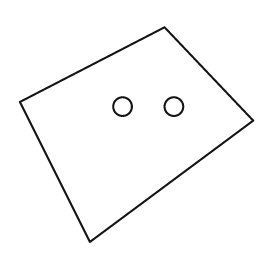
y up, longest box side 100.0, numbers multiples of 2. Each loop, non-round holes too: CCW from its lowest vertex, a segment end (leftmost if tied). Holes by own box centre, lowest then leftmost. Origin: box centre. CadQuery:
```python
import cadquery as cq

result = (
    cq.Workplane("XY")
    .moveTo(-20.0, -46.0)
    .lineTo(50.0, 6.0)
    .lineTo(12.0, 46.0)
    .lineTo(-50.0, 14.0)
    .close()
    .moveTo(-6.0, 12.0)
    .circle(4.0)
    .moveTo(16.0, 12.0)
    .circle(4.0)
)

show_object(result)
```